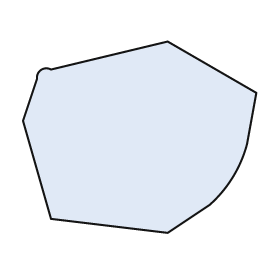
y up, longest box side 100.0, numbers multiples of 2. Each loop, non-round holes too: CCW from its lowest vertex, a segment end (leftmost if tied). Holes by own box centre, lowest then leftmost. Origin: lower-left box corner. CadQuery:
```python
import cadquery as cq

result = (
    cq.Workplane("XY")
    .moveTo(62.0, 0.0)
    .lineTo(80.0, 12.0)
    .threePointArc((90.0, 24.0), (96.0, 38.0))
    .lineTo(100.0, 60.0)
    .lineTo(62.0, 82.0)
    .lineTo(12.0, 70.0)
    .threePointArc((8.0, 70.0), (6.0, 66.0))
    .lineTo(0.0, 48.0)
    .lineTo(12.0, 6.0)
    .close()
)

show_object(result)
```